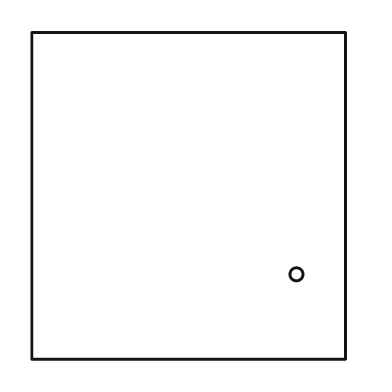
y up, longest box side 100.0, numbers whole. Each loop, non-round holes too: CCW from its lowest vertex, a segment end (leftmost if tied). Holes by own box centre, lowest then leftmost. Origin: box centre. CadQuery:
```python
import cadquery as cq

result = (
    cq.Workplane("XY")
    .moveTo(-48.0, -50.0)
    .lineTo(48.0, -50.0)
    .lineTo(48.0, 50.0)
    .lineTo(-48.0, 50.0)
    .close()
    .moveTo(33.0, -24.0)
    .circle(2.0)
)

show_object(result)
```